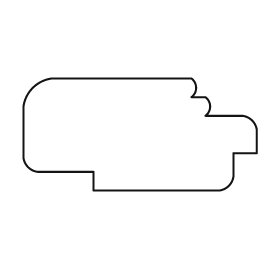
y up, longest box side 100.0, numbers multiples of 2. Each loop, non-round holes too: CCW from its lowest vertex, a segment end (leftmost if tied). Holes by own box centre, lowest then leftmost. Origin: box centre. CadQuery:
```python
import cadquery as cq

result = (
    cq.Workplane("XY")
    .moveTo(-20.0, -24.0)
    .lineTo(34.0, -24.0)
    .threePointArc((38.0, -22.0), (40.0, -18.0))
    .lineTo(40.0, -8.0)
    .lineTo(50.0, -8.0)
    .lineTo(50.0, 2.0)
    .threePointArc((48.0, 6.0), (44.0, 8.0))
    .lineTo(28.0, 8.0)
    .threePointArc((30.0, 12.0), (28.0, 16.0))
    .lineTo(22.0, 16.0)
    .threePointArc((24.0, 20.0), (22.0, 24.0))
    .lineTo(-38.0, 24.0)
    .threePointArc((-46.0, 20.0), (-50.0, 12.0))
    .lineTo(-50.0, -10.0)
    .threePointArc((-48.0, -14.0), (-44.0, -16.0))
    .lineTo(-20.0, -16.0)
    .close()
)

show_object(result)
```